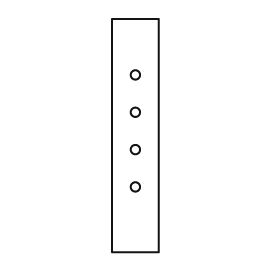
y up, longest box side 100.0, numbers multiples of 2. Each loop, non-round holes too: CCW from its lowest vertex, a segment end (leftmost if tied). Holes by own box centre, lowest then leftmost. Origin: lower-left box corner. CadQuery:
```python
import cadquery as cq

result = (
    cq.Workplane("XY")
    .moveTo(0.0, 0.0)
    .lineTo(20.0, 0.0)
    .lineTo(20.0, 100.0)
    .lineTo(0.0, 100.0)
    .close()
    .moveTo(10.0, 28.0)
    .circle(2.0)
    .moveTo(10.0, 44.0)
    .circle(2.0)
    .moveTo(10.0, 60.0)
    .circle(2.0)
    .moveTo(10.0, 76.0)
    .circle(2.0)
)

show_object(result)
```